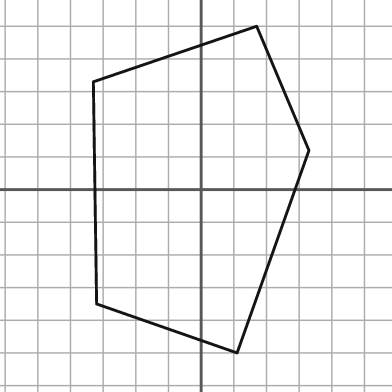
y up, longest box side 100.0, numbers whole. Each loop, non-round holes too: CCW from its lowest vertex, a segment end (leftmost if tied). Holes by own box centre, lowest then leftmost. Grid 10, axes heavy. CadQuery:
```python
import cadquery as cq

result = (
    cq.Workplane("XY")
    .moveTo(11.0, -50.0)
    .lineTo(33.0, 12.0)
    .lineTo(17.0, 50.0)
    .lineTo(-33.0, 33.0)
    .lineTo(-32.0, -35.0)
    .close()
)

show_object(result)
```